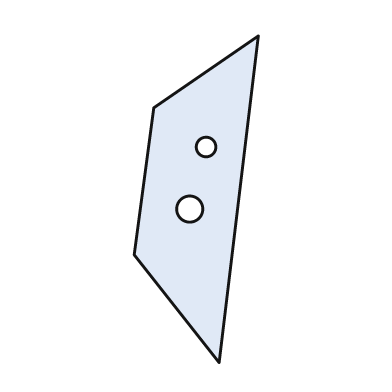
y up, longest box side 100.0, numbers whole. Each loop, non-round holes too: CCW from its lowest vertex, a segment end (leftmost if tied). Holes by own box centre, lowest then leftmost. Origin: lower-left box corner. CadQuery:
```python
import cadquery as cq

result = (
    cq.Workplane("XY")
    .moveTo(26.0, 0.0)
    .lineTo(38.0, 100.0)
    .lineTo(6.0, 78.0)
    .lineTo(0.0, 33.0)
    .close()
    .moveTo(17.0, 47.0)
    .circle(4.0)
    .moveTo(22.0, 66.0)
    .circle(3.0)
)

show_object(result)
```